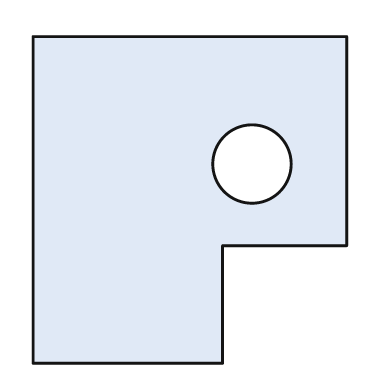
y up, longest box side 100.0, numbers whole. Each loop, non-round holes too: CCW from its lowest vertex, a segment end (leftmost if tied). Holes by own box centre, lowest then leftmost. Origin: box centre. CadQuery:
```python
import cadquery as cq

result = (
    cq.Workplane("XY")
    .moveTo(-48.0, -50.0)
    .lineTo(10.0, -50.0)
    .lineTo(10.0, -14.0)
    .lineTo(48.0, -14.0)
    .lineTo(48.0, 50.0)
    .lineTo(-48.0, 50.0)
    .close()
    .moveTo(19.0, 11.0)
    .circle(12.0)
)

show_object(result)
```